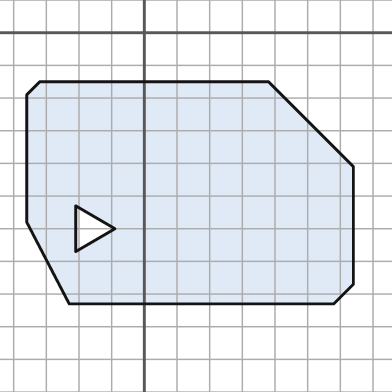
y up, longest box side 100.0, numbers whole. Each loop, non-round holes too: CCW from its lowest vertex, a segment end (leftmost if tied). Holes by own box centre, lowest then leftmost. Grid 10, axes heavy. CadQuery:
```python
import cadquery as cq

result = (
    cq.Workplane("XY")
    .moveTo(-23.0, -83.0)
    .lineTo(58.0, -83.0)
    .lineTo(64.0, -77.0)
    .lineTo(64.0, -41.0)
    .lineTo(38.0, -15.0)
    .lineTo(-32.0, -15.0)
    .lineTo(-36.0, -19.0)
    .lineTo(-36.0, -58.0)
    .close()
    .moveTo(-21.0, -67.0)
    .lineTo(-9.0, -60.0)
    .lineTo(-21.0, -53.0)
    .close()
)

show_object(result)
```